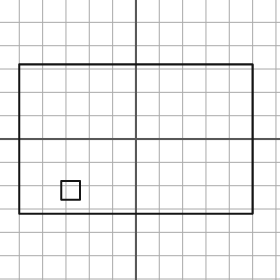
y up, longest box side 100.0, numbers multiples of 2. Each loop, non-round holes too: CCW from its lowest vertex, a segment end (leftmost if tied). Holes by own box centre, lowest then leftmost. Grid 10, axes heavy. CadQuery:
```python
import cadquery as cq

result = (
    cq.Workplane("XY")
    .moveTo(-50.0, -32.0)
    .lineTo(50.0, -32.0)
    .lineTo(50.0, 32.0)
    .lineTo(-50.0, 32.0)
    .close()
    .moveTo(-32.0, -26.0)
    .lineTo(-24.0, -26.0)
    .lineTo(-24.0, -18.0)
    .lineTo(-32.0, -18.0)
    .close()
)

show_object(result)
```